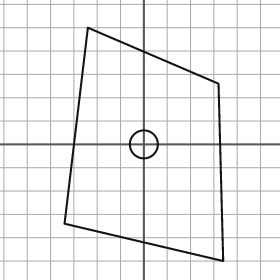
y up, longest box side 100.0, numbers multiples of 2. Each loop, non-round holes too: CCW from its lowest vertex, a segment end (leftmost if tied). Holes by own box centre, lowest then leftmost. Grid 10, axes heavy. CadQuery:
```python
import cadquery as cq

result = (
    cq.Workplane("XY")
    .moveTo(34.0, -50.0)
    .lineTo(32.0, 26.0)
    .lineTo(-24.0, 50.0)
    .lineTo(-34.0, -34.0)
    .close()
    .moveTo(0.0, 0.0)
    .circle(6.0)
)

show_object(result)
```